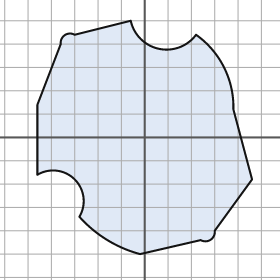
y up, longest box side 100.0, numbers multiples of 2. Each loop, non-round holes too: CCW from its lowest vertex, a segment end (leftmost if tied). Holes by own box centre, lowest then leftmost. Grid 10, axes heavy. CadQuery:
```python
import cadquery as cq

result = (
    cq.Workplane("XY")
    .moveTo(-2.0, -50.0)
    .lineTo(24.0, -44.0)
    .threePointArc((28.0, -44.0), (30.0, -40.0))
    .lineTo(46.0, -18.0)
    .lineTo(38.0, 12.0)
    .threePointArc((34.0, 30.0), (22.0, 44.0))
    .threePointArc((6.0, 38.0), (-6.0, 50.0))
    .lineTo(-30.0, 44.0)
    .threePointArc((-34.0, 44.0), (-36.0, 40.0))
    .lineTo(-46.0, 14.0)
    .lineTo(-46.0, -16.0)
    .threePointArc((-30.0, -18.0), (-28.0, -34.0))
    .threePointArc((-16.0, -44.0), (-2.0, -50.0))
    .close()
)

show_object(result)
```